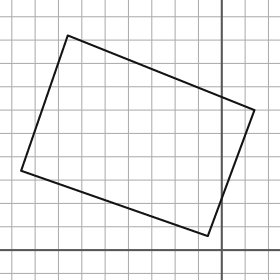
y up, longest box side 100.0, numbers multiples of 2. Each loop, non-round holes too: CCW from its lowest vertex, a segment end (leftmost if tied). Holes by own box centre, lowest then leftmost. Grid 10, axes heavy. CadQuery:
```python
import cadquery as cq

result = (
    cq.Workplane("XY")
    .moveTo(-6.0, 6.0)
    .lineTo(14.0, 60.0)
    .lineTo(-66.0, 92.0)
    .lineTo(-86.0, 34.0)
    .close()
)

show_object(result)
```